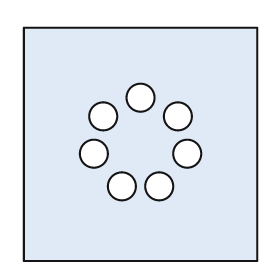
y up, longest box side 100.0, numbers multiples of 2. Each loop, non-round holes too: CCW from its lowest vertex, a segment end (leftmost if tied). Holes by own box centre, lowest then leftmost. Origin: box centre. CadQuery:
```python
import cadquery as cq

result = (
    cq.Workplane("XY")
    .moveTo(-50.0, -50.0)
    .lineTo(50.0, -50.0)
    .lineTo(50.0, 50.0)
    .lineTo(-50.0, 50.0)
    .close()
    .moveTo(-8.0, -18.0)
    .circle(6.0)
    .moveTo(8.0, -18.0)
    .circle(6.0)
    .moveTo(-20.0, -4.0)
    .circle(6.0)
    .moveTo(20.0, -4.0)
    .circle(6.0)
    .moveTo(-16.0, 12.0)
    .circle(6.0)
    .moveTo(16.0, 12.0)
    .circle(6.0)
    .moveTo(0.0, 20.0)
    .circle(6.0)
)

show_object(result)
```